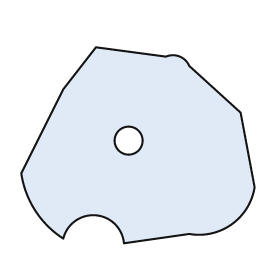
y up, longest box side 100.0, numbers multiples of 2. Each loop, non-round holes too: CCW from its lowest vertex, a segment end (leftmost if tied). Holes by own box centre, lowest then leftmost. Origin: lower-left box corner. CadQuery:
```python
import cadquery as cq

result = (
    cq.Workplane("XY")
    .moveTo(44.0, 0.0)
    .lineTo(72.0, 4.0)
    .threePointArc((90.0, 8.0), (100.0, 24.0))
    .lineTo(94.0, 56.0)
    .lineTo(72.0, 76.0)
    .threePointArc((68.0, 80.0), (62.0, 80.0))
    .lineTo(32.0, 84.0)
    .lineTo(18.0, 66.0)
    .lineTo(0.0, 30.0)
    .threePointArc((6.0, 14.0), (18.0, 2.0))
    .threePointArc((32.0, 12.0), (44.0, 0.0))
    .close()
    .moveTo(46.0, 44.0)
    .circle(6.0)
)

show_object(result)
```